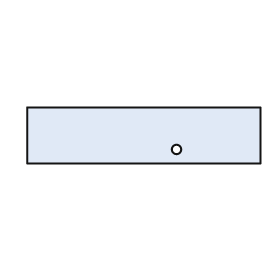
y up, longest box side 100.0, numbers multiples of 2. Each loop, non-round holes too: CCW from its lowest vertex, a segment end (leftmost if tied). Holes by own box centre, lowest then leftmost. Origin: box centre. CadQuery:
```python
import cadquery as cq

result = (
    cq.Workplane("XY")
    .moveTo(-50.0, -12.0)
    .lineTo(50.0, -12.0)
    .lineTo(50.0, 12.0)
    .lineTo(-50.0, 12.0)
    .close()
    .moveTo(14.0, -6.0)
    .circle(2.0)
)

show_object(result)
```